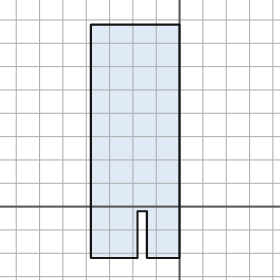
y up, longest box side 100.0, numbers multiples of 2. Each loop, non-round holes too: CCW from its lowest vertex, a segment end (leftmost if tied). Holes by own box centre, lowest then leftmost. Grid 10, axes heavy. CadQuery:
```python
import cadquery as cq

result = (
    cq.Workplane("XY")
    .moveTo(-38.0, -22.0)
    .lineTo(-18.0, -22.0)
    .lineTo(-18.0, -2.0)
    .lineTo(-14.0, -2.0)
    .lineTo(-14.0, -22.0)
    .lineTo(0.0, -22.0)
    .lineTo(0.0, 78.0)
    .lineTo(-38.0, 78.0)
    .close()
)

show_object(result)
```